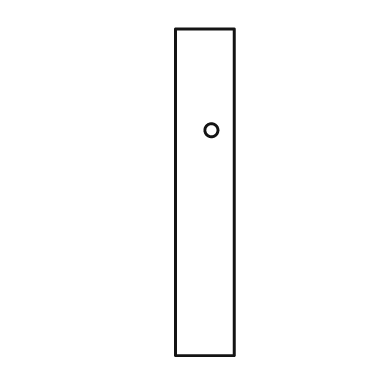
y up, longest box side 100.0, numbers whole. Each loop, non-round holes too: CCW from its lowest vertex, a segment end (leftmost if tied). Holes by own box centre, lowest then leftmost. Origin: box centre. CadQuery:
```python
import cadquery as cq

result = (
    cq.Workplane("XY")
    .moveTo(-9.0, -50.0)
    .lineTo(9.0, -50.0)
    .lineTo(9.0, 50.0)
    .lineTo(-9.0, 50.0)
    .close()
    .moveTo(2.0, 19.0)
    .circle(2.0)
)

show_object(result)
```